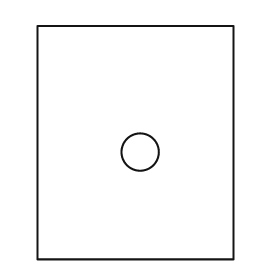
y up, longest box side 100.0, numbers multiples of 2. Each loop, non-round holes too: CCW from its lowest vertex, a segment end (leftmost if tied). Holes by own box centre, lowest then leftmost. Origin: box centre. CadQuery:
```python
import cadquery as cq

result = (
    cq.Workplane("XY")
    .moveTo(-42.0, -50.0)
    .lineTo(42.0, -50.0)
    .lineTo(42.0, 50.0)
    .lineTo(-42.0, 50.0)
    .close()
    .moveTo(2.0, -4.0)
    .circle(8.0)
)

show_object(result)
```